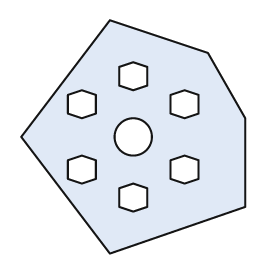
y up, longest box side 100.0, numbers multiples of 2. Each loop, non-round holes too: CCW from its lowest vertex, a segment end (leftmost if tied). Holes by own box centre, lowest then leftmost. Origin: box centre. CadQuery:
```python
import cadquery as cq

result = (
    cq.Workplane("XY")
    .moveTo(-10.0, -50.0)
    .lineTo(48.0, -30.0)
    .lineTo(48.0, 8.0)
    .lineTo(32.0, 36.0)
    .lineTo(-10.0, 50.0)
    .lineTo(-48.0, 0.0)
    .close()
    .moveTo(0.0, -32.0)
    .lineTo(6.0, -30.0)
    .lineTo(6.0, -22.0)
    .lineTo(0.0, -20.0)
    .lineTo(-6.0, -22.0)
    .lineTo(-6.0, -30.0)
    .close()
    .moveTo(-22.0, -20.0)
    .lineTo(-16.0, -18.0)
    .lineTo(-16.0, -10.0)
    .lineTo(-22.0, -8.0)
    .lineTo(-28.0, -10.0)
    .lineTo(-28.0, -18.0)
    .close()
    .moveTo(22.0, -20.0)
    .lineTo(28.0, -18.0)
    .lineTo(28.0, -10.0)
    .lineTo(22.0, -8.0)
    .lineTo(16.0, -10.0)
    .lineTo(16.0, -18.0)
    .close()
    .moveTo(0.0, 0.0)
    .circle(8.0)
    .moveTo(-22.0, 8.0)
    .lineTo(-16.0, 10.0)
    .lineTo(-16.0, 18.0)
    .lineTo(-22.0, 20.0)
    .lineTo(-28.0, 18.0)
    .lineTo(-28.0, 10.0)
    .close()
    .moveTo(22.0, 8.0)
    .lineTo(28.0, 10.0)
    .lineTo(28.0, 18.0)
    .lineTo(22.0, 20.0)
    .lineTo(16.0, 18.0)
    .lineTo(16.0, 10.0)
    .close()
    .moveTo(0.0, 20.0)
    .lineTo(6.0, 22.0)
    .lineTo(6.0, 30.0)
    .lineTo(0.0, 32.0)
    .lineTo(-6.0, 30.0)
    .lineTo(-6.0, 22.0)
    .close()
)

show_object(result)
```